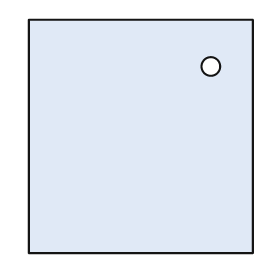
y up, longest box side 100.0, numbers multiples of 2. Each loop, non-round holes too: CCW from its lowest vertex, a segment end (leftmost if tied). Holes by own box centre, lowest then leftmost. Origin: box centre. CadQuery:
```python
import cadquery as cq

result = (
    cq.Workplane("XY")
    .moveTo(-48.0, -50.0)
    .lineTo(48.0, -50.0)
    .lineTo(48.0, 50.0)
    .lineTo(-48.0, 50.0)
    .close()
    .moveTo(30.0, 30.0)
    .circle(4.0)
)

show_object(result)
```